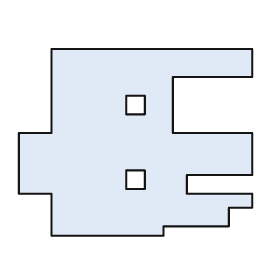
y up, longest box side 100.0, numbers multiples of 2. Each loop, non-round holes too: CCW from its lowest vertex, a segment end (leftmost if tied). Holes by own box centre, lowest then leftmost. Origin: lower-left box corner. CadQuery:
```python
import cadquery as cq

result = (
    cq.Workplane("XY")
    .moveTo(14.0, 0.0)
    .lineTo(62.0, 0.0)
    .lineTo(62.0, 4.0)
    .lineTo(90.0, 4.0)
    .lineTo(90.0, 12.0)
    .lineTo(100.0, 12.0)
    .lineTo(100.0, 18.0)
    .lineTo(72.0, 18.0)
    .lineTo(72.0, 26.0)
    .lineTo(100.0, 26.0)
    .lineTo(100.0, 44.0)
    .lineTo(66.0, 44.0)
    .lineTo(66.0, 68.0)
    .lineTo(100.0, 68.0)
    .lineTo(100.0, 80.0)
    .lineTo(14.0, 80.0)
    .lineTo(14.0, 44.0)
    .lineTo(0.0, 44.0)
    .lineTo(0.0, 18.0)
    .lineTo(14.0, 18.0)
    .close()
    .moveTo(46.0, 20.0)
    .lineTo(54.0, 20.0)
    .lineTo(54.0, 28.0)
    .lineTo(46.0, 28.0)
    .close()
    .moveTo(46.0, 52.0)
    .lineTo(54.0, 52.0)
    .lineTo(54.0, 60.0)
    .lineTo(46.0, 60.0)
    .close()
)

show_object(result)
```